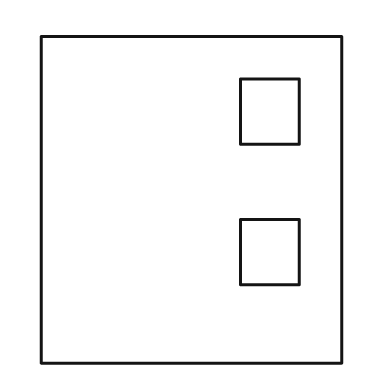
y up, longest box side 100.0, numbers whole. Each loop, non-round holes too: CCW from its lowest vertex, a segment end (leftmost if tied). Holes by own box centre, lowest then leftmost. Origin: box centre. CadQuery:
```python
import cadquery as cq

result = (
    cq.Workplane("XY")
    .moveTo(-46.0, -50.0)
    .lineTo(46.0, -50.0)
    .lineTo(46.0, 50.0)
    .lineTo(-46.0, 50.0)
    .close()
    .moveTo(15.0, -26.0)
    .lineTo(33.0, -26.0)
    .lineTo(33.0, -6.0)
    .lineTo(15.0, -6.0)
    .close()
    .moveTo(15.0, 17.0)
    .lineTo(33.0, 17.0)
    .lineTo(33.0, 37.0)
    .lineTo(15.0, 37.0)
    .close()
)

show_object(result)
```